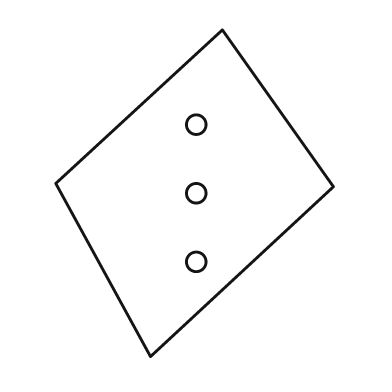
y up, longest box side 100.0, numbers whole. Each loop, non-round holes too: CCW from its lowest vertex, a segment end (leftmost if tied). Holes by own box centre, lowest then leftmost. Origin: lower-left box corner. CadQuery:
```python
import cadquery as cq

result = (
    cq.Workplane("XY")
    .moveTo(29.0, 0.0)
    .lineTo(85.0, 52.0)
    .lineTo(51.0, 100.0)
    .lineTo(0.0, 53.0)
    .close()
    .moveTo(43.0, 29.0)
    .circle(3.0)
    .moveTo(43.0, 50.0)
    .circle(3.0)
    .moveTo(43.0, 71.0)
    .circle(3.0)
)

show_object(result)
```